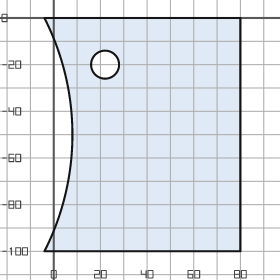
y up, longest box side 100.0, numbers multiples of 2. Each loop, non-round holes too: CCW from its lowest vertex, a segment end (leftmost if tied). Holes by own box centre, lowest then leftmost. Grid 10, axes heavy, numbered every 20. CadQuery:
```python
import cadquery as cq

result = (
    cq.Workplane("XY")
    .moveTo(-4.0, -100.0)
    .lineTo(80.0, -100.0)
    .lineTo(80.0, 0.0)
    .lineTo(-4.0, 0.0)
    .threePointArc((8.0, -50.0), (-4.0, -100.0))
    .close()
    .moveTo(22.0, -20.0)
    .circle(6.0)
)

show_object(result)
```